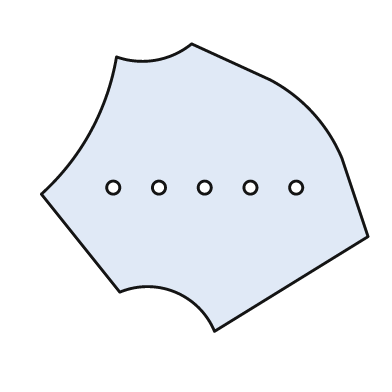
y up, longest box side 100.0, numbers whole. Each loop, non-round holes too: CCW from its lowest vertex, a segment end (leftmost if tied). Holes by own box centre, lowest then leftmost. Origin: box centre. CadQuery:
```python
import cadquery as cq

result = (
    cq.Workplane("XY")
    .moveTo(3.0, -44.0)
    .lineTo(50.0, -15.0)
    .lineTo(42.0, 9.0)
    .threePointArc((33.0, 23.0), (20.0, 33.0))
    .lineTo(-4.0, 44.0)
    .threePointArc((-15.0, 39.0), (-27.0, 40.0))
    .threePointArc((-35.0, 17.0), (-50.0, -2.0))
    .lineTo(-26.0, -32.0)
    .threePointArc((-9.0, -32.0), (3.0, -44.0))
    .close()
    .moveTo(-28.0, 0.0)
    .circle(2.0)
    .moveTo(-14.0, 0.0)
    .circle(2.0)
    .moveTo(0.0, 0.0)
    .circle(2.0)
    .moveTo(14.0, 0.0)
    .circle(2.0)
    .moveTo(28.0, 0.0)
    .circle(2.0)
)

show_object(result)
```